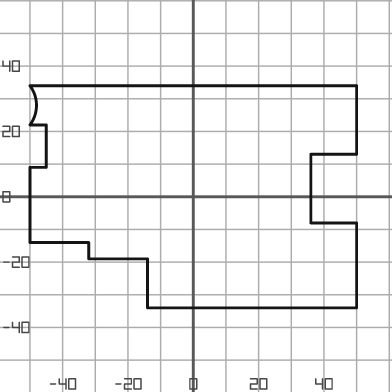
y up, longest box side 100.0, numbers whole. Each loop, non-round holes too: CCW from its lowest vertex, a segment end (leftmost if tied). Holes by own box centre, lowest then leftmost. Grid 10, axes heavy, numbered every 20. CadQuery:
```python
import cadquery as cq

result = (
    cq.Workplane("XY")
    .moveTo(-14.0, -34.0)
    .lineTo(50.0, -34.0)
    .lineTo(50.0, -8.0)
    .lineTo(36.0, -8.0)
    .lineTo(36.0, 13.0)
    .lineTo(50.0, 13.0)
    .lineTo(50.0, 34.0)
    .lineTo(-50.0, 34.0)
    .threePointArc((-48.0, 28.0), (-50.0, 22.0))
    .lineTo(-45.0, 22.0)
    .lineTo(-45.0, 9.0)
    .lineTo(-50.0, 9.0)
    .lineTo(-50.0, -14.0)
    .lineTo(-32.0, -14.0)
    .lineTo(-32.0, -19.0)
    .lineTo(-14.0, -19.0)
    .close()
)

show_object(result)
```